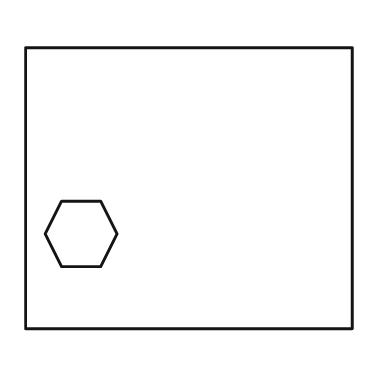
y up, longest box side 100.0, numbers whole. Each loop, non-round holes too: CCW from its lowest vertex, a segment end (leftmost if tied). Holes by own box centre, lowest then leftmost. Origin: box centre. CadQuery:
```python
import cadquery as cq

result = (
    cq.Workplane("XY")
    .moveTo(-50.0, -43.0)
    .lineTo(50.0, -43.0)
    .lineTo(50.0, 43.0)
    .lineTo(-50.0, 43.0)
    .close()
    .moveTo(-39.0, -24.0)
    .lineTo(-27.0, -24.0)
    .lineTo(-22.0, -14.0)
    .lineTo(-27.0, -4.0)
    .lineTo(-39.0, -4.0)
    .lineTo(-44.0, -14.0)
    .close()
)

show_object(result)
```